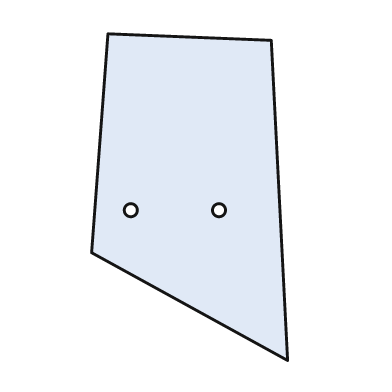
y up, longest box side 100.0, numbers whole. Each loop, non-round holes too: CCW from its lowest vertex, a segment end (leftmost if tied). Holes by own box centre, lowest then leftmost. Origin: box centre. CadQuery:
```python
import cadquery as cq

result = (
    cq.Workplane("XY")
    .moveTo(30.0, -50.0)
    .lineTo(25.0, 48.0)
    .lineTo(-25.0, 50.0)
    .lineTo(-30.0, -17.0)
    .close()
    .moveTo(-18.0, -4.0)
    .circle(2.0)
    .moveTo(9.0, -4.0)
    .circle(2.0)
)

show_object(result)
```